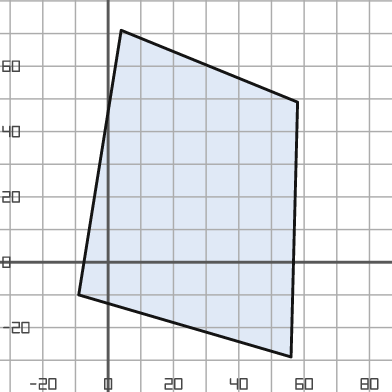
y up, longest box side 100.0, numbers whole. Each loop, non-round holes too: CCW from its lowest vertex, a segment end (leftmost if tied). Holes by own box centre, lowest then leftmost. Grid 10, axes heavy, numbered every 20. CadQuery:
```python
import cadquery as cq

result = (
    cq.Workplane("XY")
    .moveTo(56.0, -29.0)
    .lineTo(58.0, 49.0)
    .lineTo(4.0, 71.0)
    .lineTo(-9.0, -10.0)
    .close()
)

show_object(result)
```